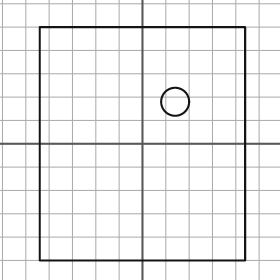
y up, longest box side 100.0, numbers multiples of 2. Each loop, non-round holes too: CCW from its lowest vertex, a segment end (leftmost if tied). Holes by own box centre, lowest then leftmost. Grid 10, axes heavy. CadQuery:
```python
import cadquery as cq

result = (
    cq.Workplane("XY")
    .moveTo(-44.0, -50.0)
    .lineTo(44.0, -50.0)
    .lineTo(44.0, 50.0)
    .lineTo(-44.0, 50.0)
    .close()
    .moveTo(14.0, 18.0)
    .circle(6.0)
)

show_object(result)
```